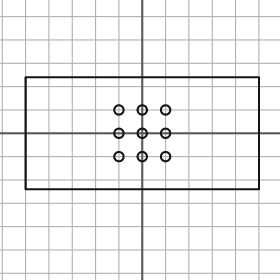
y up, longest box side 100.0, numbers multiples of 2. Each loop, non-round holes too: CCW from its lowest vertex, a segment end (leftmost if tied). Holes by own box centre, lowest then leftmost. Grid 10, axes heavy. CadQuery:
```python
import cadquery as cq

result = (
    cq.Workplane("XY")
    .moveTo(-50.0, -24.0)
    .lineTo(50.0, -24.0)
    .lineTo(50.0, 24.0)
    .lineTo(-50.0, 24.0)
    .close()
    .moveTo(-10.0, -10.0)
    .circle(2.0)
    .moveTo(0.0, -10.0)
    .circle(2.0)
    .moveTo(10.0, -10.0)
    .circle(2.0)
    .moveTo(-10.0, 0.0)
    .circle(2.0)
    .moveTo(0.0, 0.0)
    .circle(2.0)
    .moveTo(10.0, 0.0)
    .circle(2.0)
    .moveTo(-10.0, 10.0)
    .circle(2.0)
    .moveTo(0.0, 10.0)
    .circle(2.0)
    .moveTo(10.0, 10.0)
    .circle(2.0)
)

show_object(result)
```